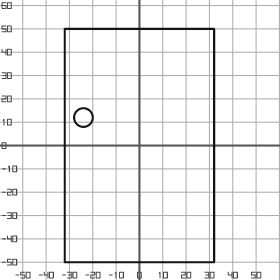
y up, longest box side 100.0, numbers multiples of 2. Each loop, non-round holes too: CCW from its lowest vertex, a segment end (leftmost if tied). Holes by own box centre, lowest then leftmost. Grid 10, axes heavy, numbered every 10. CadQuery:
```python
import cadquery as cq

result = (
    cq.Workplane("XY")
    .moveTo(-32.0, -50.0)
    .lineTo(32.0, -50.0)
    .lineTo(32.0, 50.0)
    .lineTo(-32.0, 50.0)
    .close()
    .moveTo(-24.0, 12.0)
    .circle(4.0)
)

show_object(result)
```